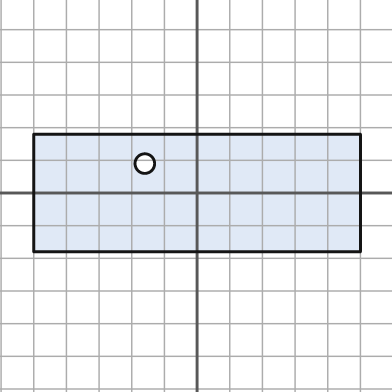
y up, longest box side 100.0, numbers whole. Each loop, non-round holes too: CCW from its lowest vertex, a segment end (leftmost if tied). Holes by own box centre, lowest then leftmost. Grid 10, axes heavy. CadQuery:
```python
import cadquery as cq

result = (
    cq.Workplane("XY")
    .moveTo(-50.0, -18.0)
    .lineTo(50.0, -18.0)
    .lineTo(50.0, 18.0)
    .lineTo(-50.0, 18.0)
    .close()
    .moveTo(-16.0, 9.0)
    .circle(3.0)
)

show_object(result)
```